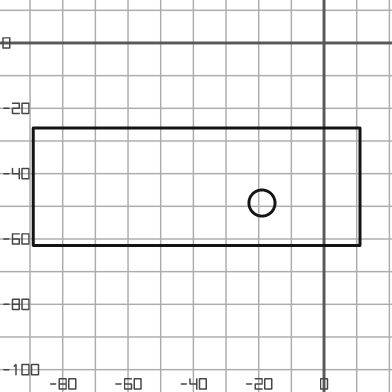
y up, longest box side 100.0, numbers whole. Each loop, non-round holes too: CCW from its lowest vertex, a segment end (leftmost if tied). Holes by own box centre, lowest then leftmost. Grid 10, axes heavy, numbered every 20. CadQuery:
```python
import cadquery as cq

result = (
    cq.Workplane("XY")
    .moveTo(-89.0, -62.0)
    .lineTo(11.0, -62.0)
    .lineTo(11.0, -26.0)
    .lineTo(-89.0, -26.0)
    .close()
    .moveTo(-19.0, -49.0)
    .circle(4.0)
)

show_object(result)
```